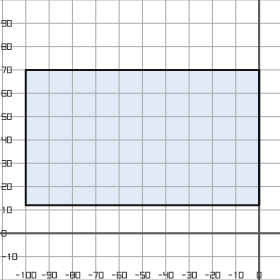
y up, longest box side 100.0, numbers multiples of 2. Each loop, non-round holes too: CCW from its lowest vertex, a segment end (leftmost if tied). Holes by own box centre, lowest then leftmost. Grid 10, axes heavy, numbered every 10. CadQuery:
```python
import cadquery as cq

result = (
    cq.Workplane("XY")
    .moveTo(-100.0, 12.0)
    .lineTo(0.0, 12.0)
    .lineTo(0.0, 70.0)
    .lineTo(-100.0, 70.0)
    .close()
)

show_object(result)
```